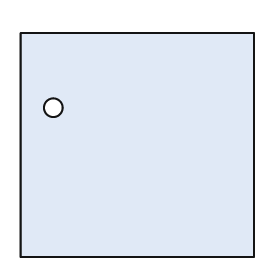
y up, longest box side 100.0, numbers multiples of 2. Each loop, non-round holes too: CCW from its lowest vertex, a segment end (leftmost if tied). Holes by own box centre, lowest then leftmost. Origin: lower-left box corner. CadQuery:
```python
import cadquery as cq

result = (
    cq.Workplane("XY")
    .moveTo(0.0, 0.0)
    .lineTo(100.0, 0.0)
    .lineTo(100.0, 96.0)
    .lineTo(0.0, 96.0)
    .close()
    .moveTo(14.0, 64.0)
    .circle(4.0)
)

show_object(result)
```